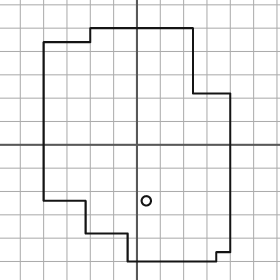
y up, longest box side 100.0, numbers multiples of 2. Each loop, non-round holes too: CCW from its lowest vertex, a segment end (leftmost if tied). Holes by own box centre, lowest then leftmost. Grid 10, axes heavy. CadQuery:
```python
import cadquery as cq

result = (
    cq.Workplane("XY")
    .moveTo(-4.0, -50.0)
    .lineTo(34.0, -50.0)
    .lineTo(34.0, -46.0)
    .lineTo(40.0, -46.0)
    .lineTo(40.0, 22.0)
    .lineTo(24.0, 22.0)
    .lineTo(24.0, 50.0)
    .lineTo(-20.0, 50.0)
    .lineTo(-20.0, 44.0)
    .lineTo(-40.0, 44.0)
    .lineTo(-40.0, -24.0)
    .lineTo(-22.0, -24.0)
    .lineTo(-22.0, -38.0)
    .lineTo(-4.0, -38.0)
    .close()
    .moveTo(4.0, -24.0)
    .circle(2.0)
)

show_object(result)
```